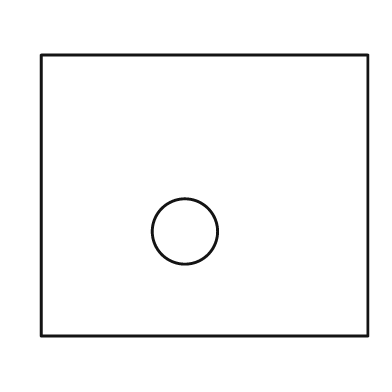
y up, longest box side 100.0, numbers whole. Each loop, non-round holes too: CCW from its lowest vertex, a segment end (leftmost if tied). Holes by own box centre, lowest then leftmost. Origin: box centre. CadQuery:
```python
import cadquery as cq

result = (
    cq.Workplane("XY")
    .moveTo(-50.0, -43.0)
    .lineTo(50.0, -43.0)
    .lineTo(50.0, 43.0)
    .lineTo(-50.0, 43.0)
    .close()
    .moveTo(-6.0, -11.0)
    .circle(10.0)
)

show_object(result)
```